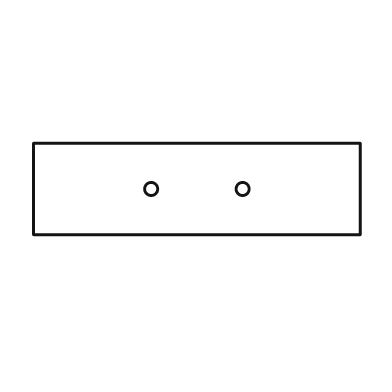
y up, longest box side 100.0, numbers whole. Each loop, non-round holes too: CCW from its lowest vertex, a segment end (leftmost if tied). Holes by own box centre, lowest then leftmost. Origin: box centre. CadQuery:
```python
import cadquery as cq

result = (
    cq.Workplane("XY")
    .moveTo(-50.0, -14.0)
    .lineTo(50.0, -14.0)
    .lineTo(50.0, 14.0)
    .lineTo(-50.0, 14.0)
    .close()
    .moveTo(-14.0, 0.0)
    .circle(2.0)
    .moveTo(14.0, 0.0)
    .circle(2.0)
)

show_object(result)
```